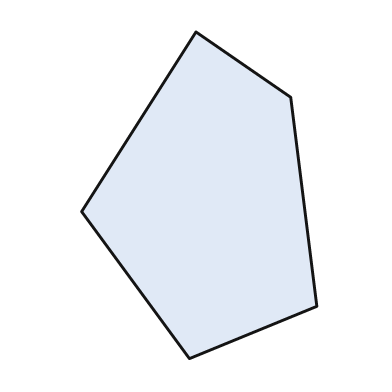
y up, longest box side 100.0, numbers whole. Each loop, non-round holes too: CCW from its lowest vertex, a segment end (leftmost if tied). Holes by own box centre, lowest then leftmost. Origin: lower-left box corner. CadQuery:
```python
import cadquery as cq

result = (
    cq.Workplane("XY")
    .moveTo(33.0, 0.0)
    .lineTo(72.0, 16.0)
    .lineTo(64.0, 80.0)
    .lineTo(35.0, 100.0)
    .lineTo(0.0, 45.0)
    .close()
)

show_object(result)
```